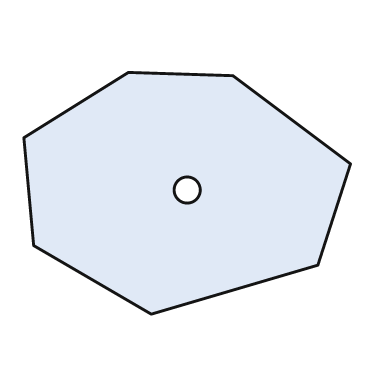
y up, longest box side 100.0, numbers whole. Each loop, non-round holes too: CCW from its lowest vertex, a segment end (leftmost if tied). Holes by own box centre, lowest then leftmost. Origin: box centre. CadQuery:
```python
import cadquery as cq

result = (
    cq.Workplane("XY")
    .moveTo(-11.0, -37.0)
    .lineTo(40.0, -22.0)
    .lineTo(50.0, 9.0)
    .lineTo(14.0, 36.0)
    .lineTo(-18.0, 37.0)
    .lineTo(-50.0, 17.0)
    .lineTo(-47.0, -16.0)
    .close()
    .moveTo(0.0, 1.0)
    .circle(4.0)
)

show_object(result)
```